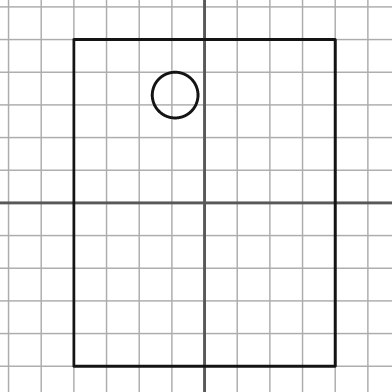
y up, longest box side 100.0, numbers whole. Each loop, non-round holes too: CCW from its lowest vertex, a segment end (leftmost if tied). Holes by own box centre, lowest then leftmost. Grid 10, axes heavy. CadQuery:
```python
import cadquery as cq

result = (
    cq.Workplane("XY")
    .moveTo(-40.0, -50.0)
    .lineTo(40.0, -50.0)
    .lineTo(40.0, 50.0)
    .lineTo(-40.0, 50.0)
    .close()
    .moveTo(-9.0, 33.0)
    .circle(7.0)
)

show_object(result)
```